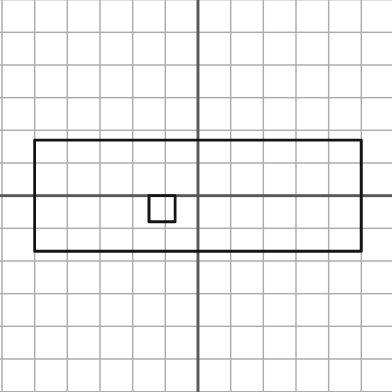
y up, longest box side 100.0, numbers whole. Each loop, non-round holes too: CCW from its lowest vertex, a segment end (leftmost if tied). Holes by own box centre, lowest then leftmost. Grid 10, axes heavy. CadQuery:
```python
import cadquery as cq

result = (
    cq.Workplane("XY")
    .moveTo(-50.0, -17.0)
    .lineTo(50.0, -17.0)
    .lineTo(50.0, 17.0)
    .lineTo(-50.0, 17.0)
    .close()
    .moveTo(-15.0, -8.0)
    .lineTo(-7.0, -8.0)
    .lineTo(-7.0, 0.0)
    .lineTo(-15.0, 0.0)
    .close()
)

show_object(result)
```